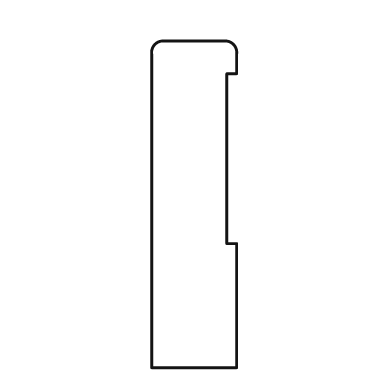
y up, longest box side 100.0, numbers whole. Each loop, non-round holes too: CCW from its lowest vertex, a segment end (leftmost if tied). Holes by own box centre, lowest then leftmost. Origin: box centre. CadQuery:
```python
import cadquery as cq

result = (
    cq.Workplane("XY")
    .moveTo(-13.0, -50.0)
    .lineTo(13.0, -50.0)
    .lineTo(13.0, -12.0)
    .lineTo(10.0, -12.0)
    .lineTo(10.0, 40.0)
    .lineTo(13.0, 40.0)
    .lineTo(13.0, 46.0)
    .threePointArc((12.0, 49.0), (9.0, 50.0))
    .lineTo(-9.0, 50.0)
    .threePointArc((-12.0, 49.0), (-13.0, 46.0))
    .close()
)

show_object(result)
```